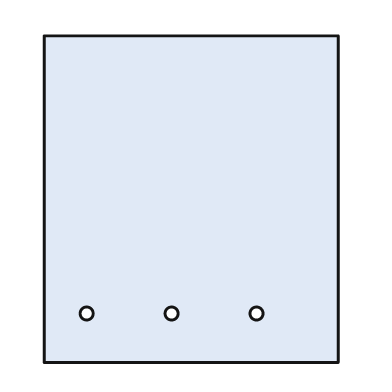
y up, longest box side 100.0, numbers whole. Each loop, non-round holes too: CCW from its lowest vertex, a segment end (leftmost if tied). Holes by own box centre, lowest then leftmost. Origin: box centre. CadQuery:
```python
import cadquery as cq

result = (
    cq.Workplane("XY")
    .moveTo(-45.0, -50.0)
    .lineTo(45.0, -50.0)
    .lineTo(45.0, 50.0)
    .lineTo(-45.0, 50.0)
    .close()
    .moveTo(-32.0, -35.0)
    .circle(2.0)
    .moveTo(-6.0, -35.0)
    .circle(2.0)
    .moveTo(20.0, -35.0)
    .circle(2.0)
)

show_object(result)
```